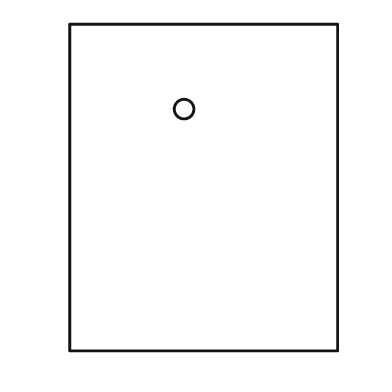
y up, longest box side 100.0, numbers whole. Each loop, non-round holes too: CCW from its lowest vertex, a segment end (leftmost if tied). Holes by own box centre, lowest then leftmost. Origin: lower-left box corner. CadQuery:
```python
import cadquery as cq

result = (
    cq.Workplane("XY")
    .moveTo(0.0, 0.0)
    .lineTo(82.0, 0.0)
    .lineTo(82.0, 100.0)
    .lineTo(0.0, 100.0)
    .close()
    .moveTo(35.0, 74.0)
    .circle(3.0)
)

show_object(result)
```